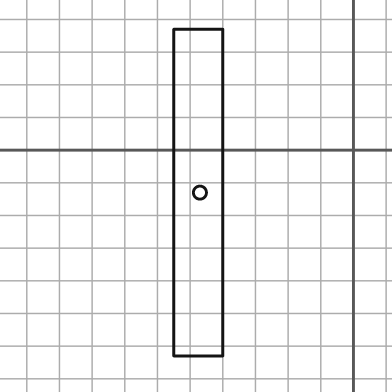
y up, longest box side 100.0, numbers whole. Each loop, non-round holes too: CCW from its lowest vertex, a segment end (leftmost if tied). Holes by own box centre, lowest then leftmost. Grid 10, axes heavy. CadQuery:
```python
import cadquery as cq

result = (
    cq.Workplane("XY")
    .moveTo(-55.0, -63.0)
    .lineTo(-40.0, -63.0)
    .lineTo(-40.0, 37.0)
    .lineTo(-55.0, 37.0)
    .close()
    .moveTo(-47.0, -13.0)
    .circle(2.0)
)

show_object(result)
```